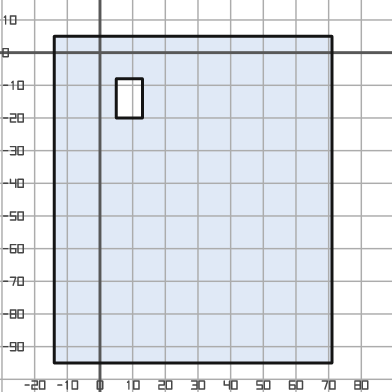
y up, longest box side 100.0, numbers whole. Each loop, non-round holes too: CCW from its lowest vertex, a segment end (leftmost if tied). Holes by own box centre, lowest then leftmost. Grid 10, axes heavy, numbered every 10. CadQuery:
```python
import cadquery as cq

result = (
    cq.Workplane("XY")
    .moveTo(-14.0, -95.0)
    .lineTo(71.0, -95.0)
    .lineTo(71.0, 5.0)
    .lineTo(-14.0, 5.0)
    .close()
    .moveTo(5.0, -20.0)
    .lineTo(13.0, -20.0)
    .lineTo(13.0, -8.0)
    .lineTo(5.0, -8.0)
    .close()
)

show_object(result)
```